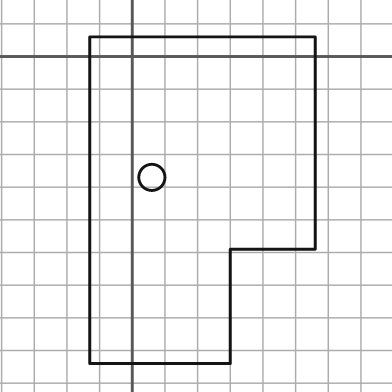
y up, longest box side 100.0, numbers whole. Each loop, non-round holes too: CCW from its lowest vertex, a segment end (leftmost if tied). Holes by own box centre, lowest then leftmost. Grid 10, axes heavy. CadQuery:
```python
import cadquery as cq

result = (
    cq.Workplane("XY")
    .moveTo(-13.0, -94.0)
    .lineTo(30.0, -94.0)
    .lineTo(30.0, -59.0)
    .lineTo(56.0, -59.0)
    .lineTo(56.0, 6.0)
    .lineTo(-13.0, 6.0)
    .close()
    .moveTo(6.0, -37.0)
    .circle(4.0)
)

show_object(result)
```